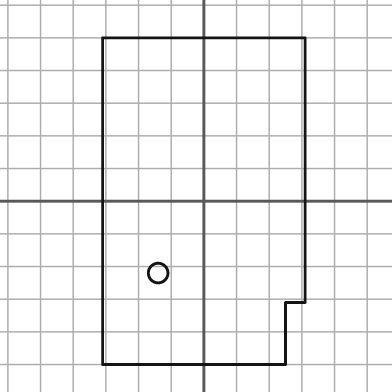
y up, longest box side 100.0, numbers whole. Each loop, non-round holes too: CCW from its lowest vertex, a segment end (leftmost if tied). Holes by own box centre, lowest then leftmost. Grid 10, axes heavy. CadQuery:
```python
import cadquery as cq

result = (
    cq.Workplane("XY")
    .moveTo(-31.0, -50.0)
    .lineTo(25.0, -50.0)
    .lineTo(25.0, -31.0)
    .lineTo(31.0, -31.0)
    .lineTo(31.0, 50.0)
    .lineTo(-31.0, 50.0)
    .close()
    .moveTo(-14.0, -22.0)
    .circle(3.0)
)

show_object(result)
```